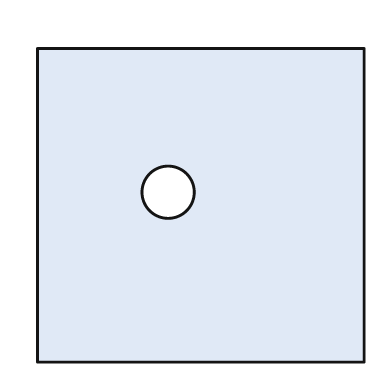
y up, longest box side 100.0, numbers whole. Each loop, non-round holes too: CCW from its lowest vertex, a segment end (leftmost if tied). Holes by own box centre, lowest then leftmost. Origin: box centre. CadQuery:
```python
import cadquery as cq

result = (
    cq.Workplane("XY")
    .moveTo(-50.0, -48.0)
    .lineTo(50.0, -48.0)
    .lineTo(50.0, 48.0)
    .lineTo(-50.0, 48.0)
    .close()
    .moveTo(-10.0, 4.0)
    .circle(8.0)
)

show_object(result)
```